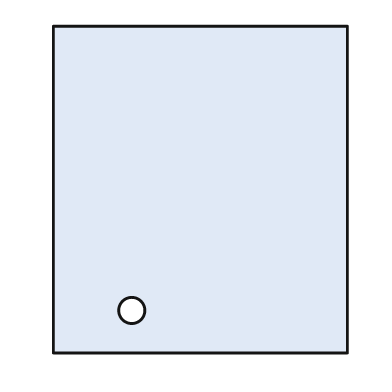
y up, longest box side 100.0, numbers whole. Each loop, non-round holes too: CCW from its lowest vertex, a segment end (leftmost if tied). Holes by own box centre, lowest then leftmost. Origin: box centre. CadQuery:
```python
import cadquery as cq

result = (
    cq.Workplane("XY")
    .moveTo(-45.0, -50.0)
    .lineTo(45.0, -50.0)
    .lineTo(45.0, 50.0)
    .lineTo(-45.0, 50.0)
    .close()
    .moveTo(-21.0, -37.0)
    .circle(4.0)
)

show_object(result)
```